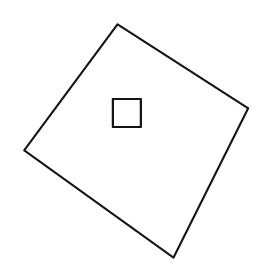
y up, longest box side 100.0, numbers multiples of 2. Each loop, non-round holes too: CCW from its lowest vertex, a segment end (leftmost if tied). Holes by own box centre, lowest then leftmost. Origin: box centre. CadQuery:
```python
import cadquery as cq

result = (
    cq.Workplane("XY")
    .moveTo(16.0, -50.0)
    .lineTo(48.0, 14.0)
    .lineTo(-8.0, 50.0)
    .lineTo(-48.0, -4.0)
    .close()
    .moveTo(-10.0, 6.0)
    .lineTo(2.0, 6.0)
    .lineTo(2.0, 18.0)
    .lineTo(-10.0, 18.0)
    .close()
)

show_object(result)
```